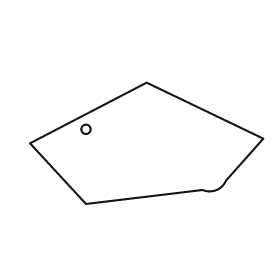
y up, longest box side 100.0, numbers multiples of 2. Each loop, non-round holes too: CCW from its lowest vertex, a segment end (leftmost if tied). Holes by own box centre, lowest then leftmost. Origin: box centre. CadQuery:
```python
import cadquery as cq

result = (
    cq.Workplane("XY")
    .moveTo(-26.0, -26.0)
    .lineTo(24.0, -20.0)
    .threePointArc((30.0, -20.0), (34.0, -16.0))
    .lineTo(50.0, 2.0)
    .lineTo(0.0, 26.0)
    .lineTo(-50.0, 0.0)
    .close()
    .moveTo(-26.0, 6.0)
    .circle(2.0)
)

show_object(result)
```